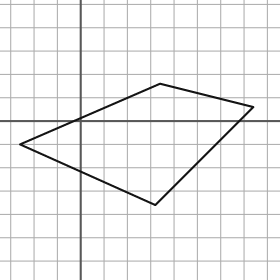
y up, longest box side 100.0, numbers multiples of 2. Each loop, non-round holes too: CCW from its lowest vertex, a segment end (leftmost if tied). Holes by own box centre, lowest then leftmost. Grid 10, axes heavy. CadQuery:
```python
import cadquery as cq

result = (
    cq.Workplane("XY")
    .moveTo(32.0, -36.0)
    .lineTo(74.0, 6.0)
    .lineTo(34.0, 16.0)
    .lineTo(-26.0, -10.0)
    .close()
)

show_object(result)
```